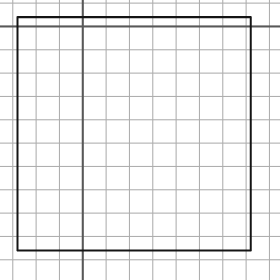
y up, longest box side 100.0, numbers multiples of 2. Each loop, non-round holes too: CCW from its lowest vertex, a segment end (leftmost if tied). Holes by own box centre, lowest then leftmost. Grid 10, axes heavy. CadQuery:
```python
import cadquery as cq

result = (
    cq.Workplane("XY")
    .moveTo(-28.0, -96.0)
    .lineTo(72.0, -96.0)
    .lineTo(72.0, 4.0)
    .lineTo(-28.0, 4.0)
    .close()
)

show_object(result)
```